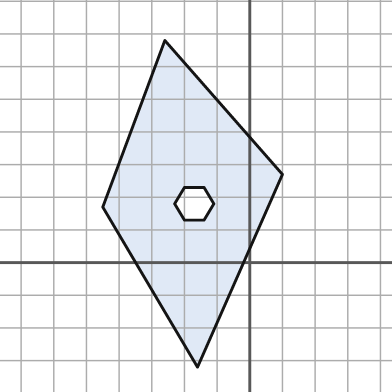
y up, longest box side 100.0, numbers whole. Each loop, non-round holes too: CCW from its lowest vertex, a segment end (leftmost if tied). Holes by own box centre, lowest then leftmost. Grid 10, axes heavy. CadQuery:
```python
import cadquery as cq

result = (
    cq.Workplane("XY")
    .moveTo(-16.0, -32.0)
    .lineTo(10.0, 27.0)
    .lineTo(-26.0, 68.0)
    .lineTo(-45.0, 17.0)
    .close()
    .moveTo(-20.0, 13.0)
    .lineTo(-14.0, 13.0)
    .lineTo(-11.0, 18.0)
    .lineTo(-14.0, 23.0)
    .lineTo(-20.0, 23.0)
    .lineTo(-23.0, 18.0)
    .close()
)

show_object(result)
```